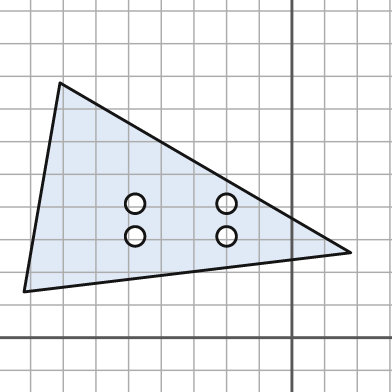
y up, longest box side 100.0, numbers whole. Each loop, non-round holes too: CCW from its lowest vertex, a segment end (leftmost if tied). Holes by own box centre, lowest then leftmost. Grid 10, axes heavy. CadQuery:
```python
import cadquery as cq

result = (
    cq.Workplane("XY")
    .moveTo(-82.0, 14.0)
    .lineTo(18.0, 26.0)
    .lineTo(-71.0, 78.0)
    .close()
    .moveTo(-48.0, 31.0)
    .circle(3.0)
    .moveTo(-20.0, 31.0)
    .circle(3.0)
    .moveTo(-48.0, 41.0)
    .circle(3.0)
    .moveTo(-20.0, 41.0)
    .circle(3.0)
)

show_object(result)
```